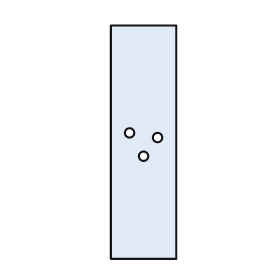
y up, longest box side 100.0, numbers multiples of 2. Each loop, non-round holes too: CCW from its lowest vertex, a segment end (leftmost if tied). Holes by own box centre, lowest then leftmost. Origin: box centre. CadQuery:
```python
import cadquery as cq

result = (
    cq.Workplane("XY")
    .moveTo(-14.0, -50.0)
    .lineTo(14.0, -50.0)
    .lineTo(14.0, 50.0)
    .lineTo(-14.0, 50.0)
    .close()
    .moveTo(0.0, -6.0)
    .circle(2.0)
    .moveTo(6.0, 2.0)
    .circle(2.0)
    .moveTo(-6.0, 4.0)
    .circle(2.0)
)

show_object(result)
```